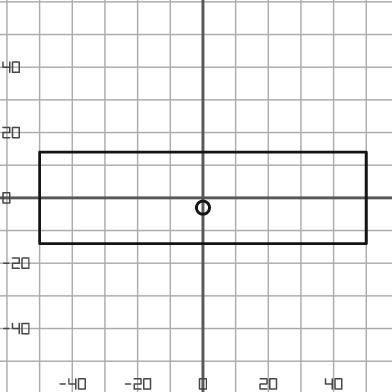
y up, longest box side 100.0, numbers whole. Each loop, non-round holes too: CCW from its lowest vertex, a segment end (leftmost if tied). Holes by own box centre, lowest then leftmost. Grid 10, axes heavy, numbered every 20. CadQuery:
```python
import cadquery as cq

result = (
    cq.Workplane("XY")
    .moveTo(-50.0, -14.0)
    .lineTo(50.0, -14.0)
    .lineTo(50.0, 14.0)
    .lineTo(-50.0, 14.0)
    .close()
    .moveTo(0.0, -3.0)
    .circle(2.0)
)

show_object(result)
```